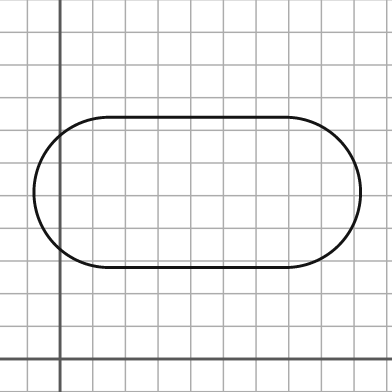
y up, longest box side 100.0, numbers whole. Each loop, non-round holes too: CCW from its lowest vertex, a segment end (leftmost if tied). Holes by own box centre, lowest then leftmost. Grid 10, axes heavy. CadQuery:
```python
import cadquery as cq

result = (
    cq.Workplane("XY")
    .moveTo(15.0, 28.0)
    .lineTo(69.0, 28.0)
    .threePointArc((92.0, 51.0), (69.0, 74.0))
    .lineTo(15.0, 74.0)
    .threePointArc((-8.0, 51.0), (15.0, 28.0))
    .close()
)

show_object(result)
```